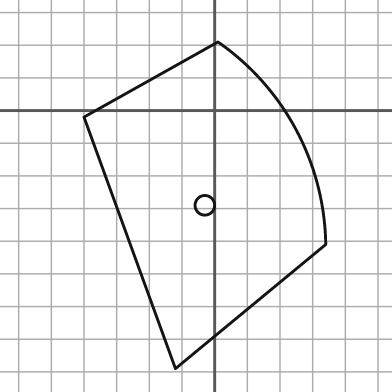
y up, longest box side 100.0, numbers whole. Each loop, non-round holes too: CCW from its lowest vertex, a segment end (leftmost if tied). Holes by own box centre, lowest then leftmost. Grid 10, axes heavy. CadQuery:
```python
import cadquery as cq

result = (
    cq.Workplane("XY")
    .moveTo(-12.0, -79.0)
    .lineTo(34.0, -41.0)
    .threePointArc((25.0, -6.0), (1.0, 21.0))
    .lineTo(-40.0, -2.0)
    .close()
    .moveTo(-3.0, -29.0)
    .circle(3.0)
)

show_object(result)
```